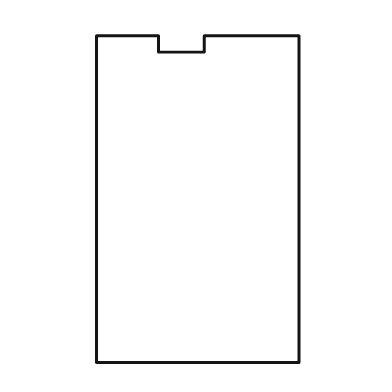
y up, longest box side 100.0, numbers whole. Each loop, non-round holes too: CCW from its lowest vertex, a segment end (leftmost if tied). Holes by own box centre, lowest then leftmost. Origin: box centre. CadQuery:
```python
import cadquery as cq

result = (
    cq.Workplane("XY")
    .moveTo(-31.0, -50.0)
    .lineTo(31.0, -50.0)
    .lineTo(31.0, 50.0)
    .lineTo(2.0, 50.0)
    .lineTo(2.0, 45.0)
    .lineTo(-12.0, 45.0)
    .lineTo(-12.0, 50.0)
    .lineTo(-31.0, 50.0)
    .close()
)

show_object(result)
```